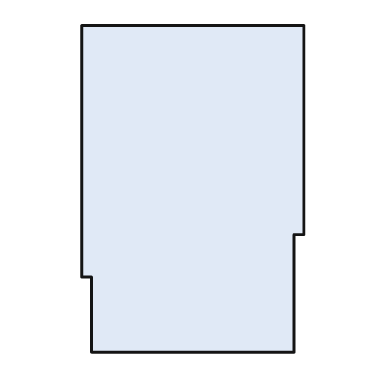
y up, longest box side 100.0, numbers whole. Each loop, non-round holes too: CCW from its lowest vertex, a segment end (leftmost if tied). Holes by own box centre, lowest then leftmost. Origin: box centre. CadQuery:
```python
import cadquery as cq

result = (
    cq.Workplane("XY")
    .moveTo(-31.0, -50.0)
    .lineTo(31.0, -50.0)
    .lineTo(31.0, -14.0)
    .lineTo(34.0, -14.0)
    .lineTo(34.0, 50.0)
    .lineTo(-34.0, 50.0)
    .lineTo(-34.0, -27.0)
    .lineTo(-31.0, -27.0)
    .close()
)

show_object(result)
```